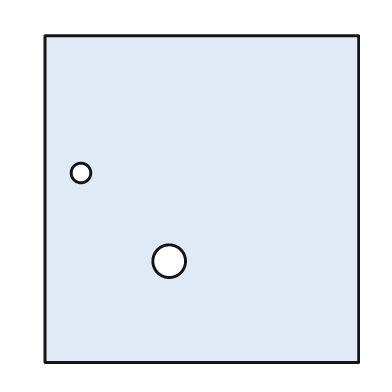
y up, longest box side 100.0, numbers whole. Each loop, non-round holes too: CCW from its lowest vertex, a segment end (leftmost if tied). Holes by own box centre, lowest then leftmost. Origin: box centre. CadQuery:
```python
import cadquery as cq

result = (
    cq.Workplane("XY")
    .moveTo(-48.0, -50.0)
    .lineTo(48.0, -50.0)
    .lineTo(48.0, 50.0)
    .lineTo(-48.0, 50.0)
    .close()
    .moveTo(-10.0, -19.0)
    .circle(5.0)
    .moveTo(-37.0, 8.0)
    .circle(3.0)
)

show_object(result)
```